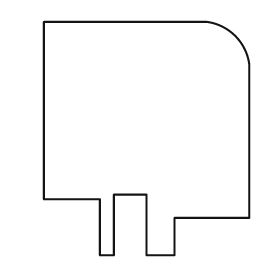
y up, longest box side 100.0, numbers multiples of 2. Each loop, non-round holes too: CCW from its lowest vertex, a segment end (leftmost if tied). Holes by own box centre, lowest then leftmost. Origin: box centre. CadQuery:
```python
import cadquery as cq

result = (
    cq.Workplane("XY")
    .moveTo(-20.0, -50.0)
    .lineTo(-14.0, -50.0)
    .lineTo(-14.0, -24.0)
    .lineTo(0.0, -24.0)
    .lineTo(0.0, -50.0)
    .lineTo(12.0, -50.0)
    .lineTo(12.0, -34.0)
    .lineTo(44.0, -34.0)
    .lineTo(44.0, 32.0)
    .threePointArc((38.0, 44.0), (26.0, 50.0))
    .lineTo(-44.0, 50.0)
    .lineTo(-44.0, -26.0)
    .lineTo(-20.0, -26.0)
    .close()
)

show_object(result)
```